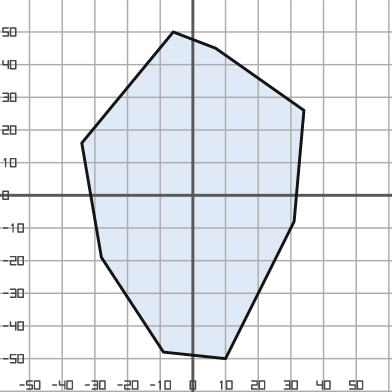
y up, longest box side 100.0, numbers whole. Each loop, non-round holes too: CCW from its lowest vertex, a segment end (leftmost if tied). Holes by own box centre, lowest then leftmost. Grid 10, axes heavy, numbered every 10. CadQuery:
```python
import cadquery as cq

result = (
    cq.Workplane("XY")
    .moveTo(10.0, -50.0)
    .lineTo(31.0, -8.0)
    .lineTo(34.0, 26.0)
    .lineTo(7.0, 45.0)
    .lineTo(-6.0, 50.0)
    .lineTo(-34.0, 16.0)
    .lineTo(-28.0, -19.0)
    .lineTo(-9.0, -48.0)
    .close()
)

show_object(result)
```